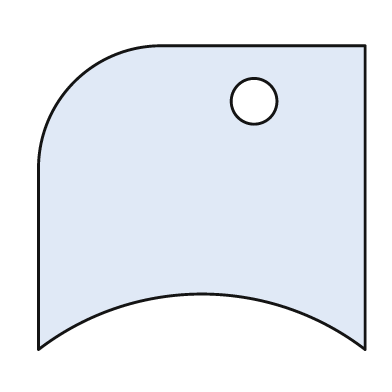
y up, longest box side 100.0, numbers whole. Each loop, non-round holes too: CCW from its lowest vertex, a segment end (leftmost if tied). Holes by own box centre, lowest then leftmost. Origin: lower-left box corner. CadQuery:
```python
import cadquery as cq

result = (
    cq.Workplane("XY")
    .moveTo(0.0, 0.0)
    .threePointArc((50.0, 17.0), (100.0, 0.0))
    .lineTo(100.0, 93.0)
    .lineTo(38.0, 93.0)
    .threePointArc((11.0, 82.0), (0.0, 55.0))
    .close()
    .moveTo(66.0, 76.0)
    .circle(7.0)
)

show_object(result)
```